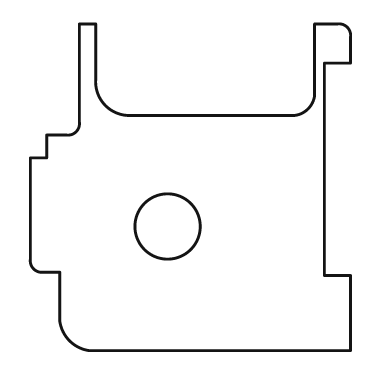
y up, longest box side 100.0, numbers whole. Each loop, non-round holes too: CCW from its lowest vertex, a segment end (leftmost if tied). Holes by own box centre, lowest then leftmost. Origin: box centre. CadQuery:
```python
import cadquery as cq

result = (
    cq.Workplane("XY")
    .moveTo(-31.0, -50.0)
    .lineTo(49.0, -50.0)
    .lineTo(49.0, -27.0)
    .lineTo(41.0, -27.0)
    .lineTo(41.0, 38.0)
    .lineTo(49.0, 38.0)
    .lineTo(49.0, 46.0)
    .threePointArc((48.0, 49.0), (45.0, 50.0))
    .lineTo(38.0, 50.0)
    .lineTo(38.0, 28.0)
    .threePointArc((36.0, 24.0), (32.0, 22.0))
    .lineTo(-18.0, 22.0)
    .threePointArc((-26.0, 25.0), (-29.0, 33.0))
    .lineTo(-29.0, 50.0)
    .lineTo(-34.0, 50.0)
    .lineTo(-34.0, 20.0)
    .threePointArc((-35.0, 17.0), (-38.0, 16.0))
    .lineTo(-44.0, 16.0)
    .lineTo(-44.0, 9.0)
    .lineTo(-49.0, 9.0)
    .lineTo(-49.0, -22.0)
    .threePointArc((-48.0, -25.0), (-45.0, -26.0))
    .lineTo(-40.0, -26.0)
    .lineTo(-40.0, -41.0)
    .threePointArc((-37.0, -47.0), (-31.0, -50.0))
    .close()
    .moveTo(-7.0, -12.0)
    .circle(10.0)
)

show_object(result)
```